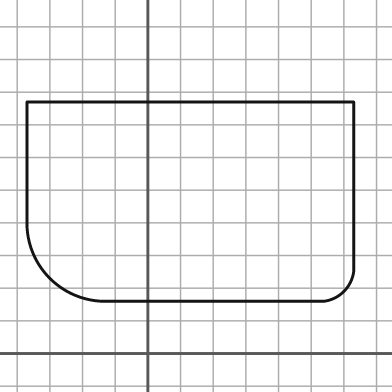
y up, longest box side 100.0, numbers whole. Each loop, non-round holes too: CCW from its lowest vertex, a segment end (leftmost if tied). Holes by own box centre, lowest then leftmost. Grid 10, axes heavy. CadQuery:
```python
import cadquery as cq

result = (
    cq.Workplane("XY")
    .moveTo(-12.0, 16.0)
    .lineTo(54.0, 16.0)
    .threePointArc((60.0, 19.0), (63.0, 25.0))
    .lineTo(63.0, 77.0)
    .lineTo(-37.0, 77.0)
    .lineTo(-37.0, 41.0)
    .threePointArc((-30.0, 23.0), (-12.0, 16.0))
    .close()
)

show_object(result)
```